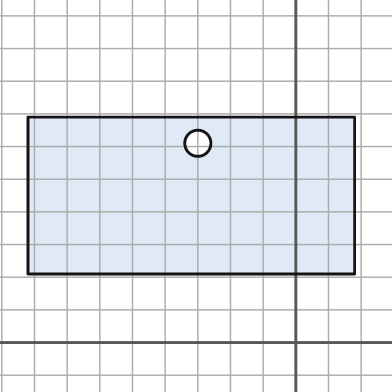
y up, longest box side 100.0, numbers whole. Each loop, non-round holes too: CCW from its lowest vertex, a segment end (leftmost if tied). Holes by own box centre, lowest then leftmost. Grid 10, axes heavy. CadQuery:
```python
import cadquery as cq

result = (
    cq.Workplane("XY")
    .moveTo(-82.0, 21.0)
    .lineTo(18.0, 21.0)
    .lineTo(18.0, 69.0)
    .lineTo(-82.0, 69.0)
    .close()
    .moveTo(-30.0, 61.0)
    .circle(4.0)
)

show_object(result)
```